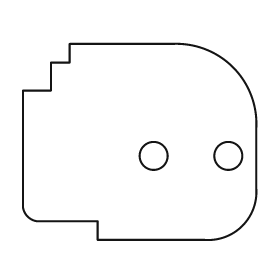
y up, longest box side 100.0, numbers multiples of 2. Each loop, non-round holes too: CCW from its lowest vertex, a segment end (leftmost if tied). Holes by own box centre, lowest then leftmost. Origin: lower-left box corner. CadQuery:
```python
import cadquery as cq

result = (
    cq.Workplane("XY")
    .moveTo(32.0, 0.0)
    .lineTo(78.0, 0.0)
    .threePointArc((94.0, 6.0), (100.0, 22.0))
    .lineTo(100.0, 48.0)
    .threePointArc((90.0, 74.0), (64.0, 84.0))
    .lineTo(20.0, 84.0)
    .lineTo(20.0, 76.0)
    .lineTo(12.0, 76.0)
    .lineTo(12.0, 64.0)
    .lineTo(0.0, 64.0)
    .lineTo(0.0, 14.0)
    .threePointArc((2.0, 10.0), (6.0, 8.0))
    .lineTo(32.0, 8.0)
    .close()
    .moveTo(56.0, 36.0)
    .circle(6.0)
    .moveTo(88.0, 36.0)
    .circle(6.0)
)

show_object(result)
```